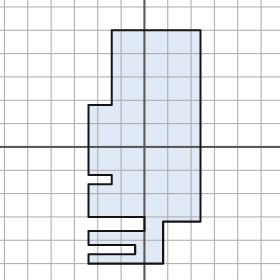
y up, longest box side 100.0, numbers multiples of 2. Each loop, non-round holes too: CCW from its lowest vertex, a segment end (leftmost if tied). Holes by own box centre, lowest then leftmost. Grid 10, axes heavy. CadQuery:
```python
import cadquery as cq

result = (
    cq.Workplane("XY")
    .moveTo(-24.0, -50.0)
    .lineTo(8.0, -50.0)
    .lineTo(8.0, -32.0)
    .lineTo(24.0, -32.0)
    .lineTo(24.0, 50.0)
    .lineTo(-14.0, 50.0)
    .lineTo(-14.0, 18.0)
    .lineTo(-24.0, 18.0)
    .lineTo(-24.0, -12.0)
    .lineTo(-14.0, -12.0)
    .lineTo(-14.0, -16.0)
    .lineTo(-24.0, -16.0)
    .lineTo(-24.0, -30.0)
    .lineTo(0.0, -30.0)
    .lineTo(0.0, -36.0)
    .lineTo(-24.0, -36.0)
    .lineTo(-24.0, -42.0)
    .lineTo(-4.0, -42.0)
    .lineTo(-4.0, -46.0)
    .lineTo(-24.0, -46.0)
    .close()
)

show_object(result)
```